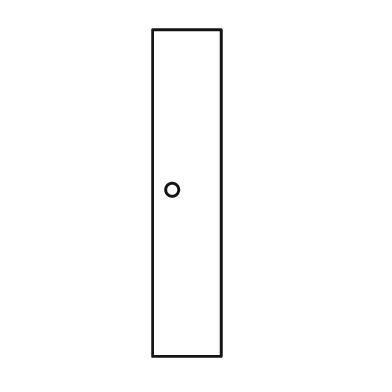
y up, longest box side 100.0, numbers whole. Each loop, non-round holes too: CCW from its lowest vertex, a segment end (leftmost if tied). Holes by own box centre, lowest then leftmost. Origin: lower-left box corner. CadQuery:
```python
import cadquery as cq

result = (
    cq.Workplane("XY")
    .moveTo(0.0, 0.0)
    .lineTo(21.0, 0.0)
    .lineTo(21.0, 100.0)
    .lineTo(0.0, 100.0)
    .close()
    .moveTo(6.0, 51.0)
    .circle(2.0)
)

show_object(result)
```